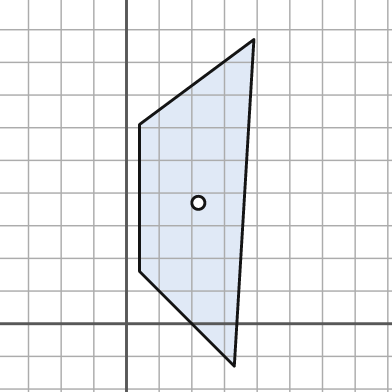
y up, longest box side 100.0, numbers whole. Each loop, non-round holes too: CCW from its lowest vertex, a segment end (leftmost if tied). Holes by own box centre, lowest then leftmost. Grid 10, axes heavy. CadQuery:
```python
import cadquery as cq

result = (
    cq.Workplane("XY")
    .moveTo(33.0, -13.0)
    .lineTo(39.0, 87.0)
    .lineTo(4.0, 61.0)
    .lineTo(4.0, 16.0)
    .close()
    .moveTo(22.0, 37.0)
    .circle(2.0)
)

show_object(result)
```